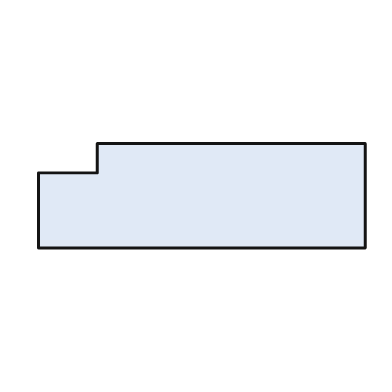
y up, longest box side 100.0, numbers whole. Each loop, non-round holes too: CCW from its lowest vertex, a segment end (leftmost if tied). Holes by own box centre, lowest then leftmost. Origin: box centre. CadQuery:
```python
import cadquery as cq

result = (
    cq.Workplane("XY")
    .moveTo(-50.0, -16.0)
    .lineTo(50.0, -16.0)
    .lineTo(50.0, 16.0)
    .lineTo(-32.0, 16.0)
    .lineTo(-32.0, 7.0)
    .lineTo(-50.0, 7.0)
    .close()
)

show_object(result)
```